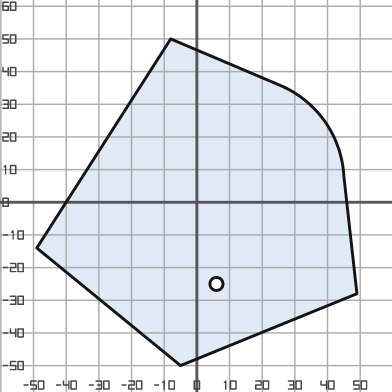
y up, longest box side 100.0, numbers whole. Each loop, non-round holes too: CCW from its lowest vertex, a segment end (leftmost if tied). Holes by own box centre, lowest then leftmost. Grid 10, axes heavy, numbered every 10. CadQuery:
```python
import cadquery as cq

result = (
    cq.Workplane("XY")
    .moveTo(-5.0, -50.0)
    .lineTo(49.0, -28.0)
    .lineTo(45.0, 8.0)
    .threePointArc((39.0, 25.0), (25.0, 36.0))
    .lineTo(-8.0, 50.0)
    .lineTo(-49.0, -14.0)
    .close()
    .moveTo(6.0, -25.0)
    .circle(2.0)
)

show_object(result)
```